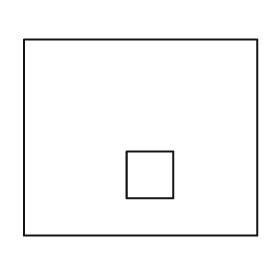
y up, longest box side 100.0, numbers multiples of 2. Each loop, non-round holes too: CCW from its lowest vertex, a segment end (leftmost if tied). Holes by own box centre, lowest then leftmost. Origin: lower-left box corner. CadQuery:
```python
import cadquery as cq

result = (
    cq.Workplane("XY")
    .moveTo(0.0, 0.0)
    .lineTo(100.0, 0.0)
    .lineTo(100.0, 84.0)
    .lineTo(0.0, 84.0)
    .close()
    .moveTo(44.0, 16.0)
    .lineTo(64.0, 16.0)
    .lineTo(64.0, 36.0)
    .lineTo(44.0, 36.0)
    .close()
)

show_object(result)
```